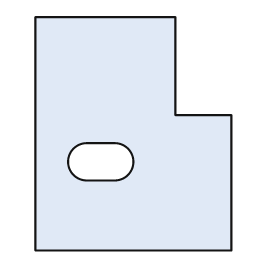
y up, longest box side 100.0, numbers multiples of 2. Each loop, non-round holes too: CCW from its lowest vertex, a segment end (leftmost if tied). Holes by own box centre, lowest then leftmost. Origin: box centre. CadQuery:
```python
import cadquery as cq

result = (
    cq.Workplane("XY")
    .moveTo(-42.0, -50.0)
    .lineTo(42.0, -50.0)
    .lineTo(42.0, 8.0)
    .lineTo(18.0, 8.0)
    .lineTo(18.0, 50.0)
    .lineTo(-42.0, 50.0)
    .close()
    .moveTo(-20.0, -20.0)
    .lineTo(-8.0, -20.0)
    .threePointArc((0.0, -12.0), (-8.0, -4.0))
    .lineTo(-20.0, -4.0)
    .threePointArc((-28.0, -12.0), (-20.0, -20.0))
    .close()
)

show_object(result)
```